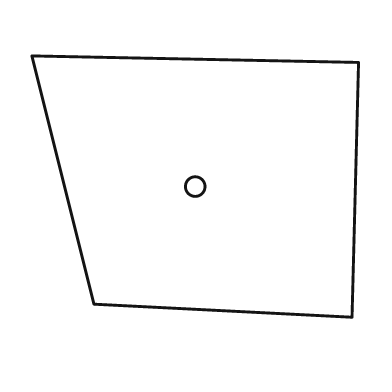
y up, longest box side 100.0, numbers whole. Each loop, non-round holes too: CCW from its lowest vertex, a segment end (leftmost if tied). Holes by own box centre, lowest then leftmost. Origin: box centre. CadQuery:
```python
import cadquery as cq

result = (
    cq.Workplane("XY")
    .moveTo(48.0, -40.0)
    .lineTo(50.0, 38.0)
    .lineTo(-50.0, 40.0)
    .lineTo(-31.0, -36.0)
    .close()
    .moveTo(0.0, 0.0)
    .circle(3.0)
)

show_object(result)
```